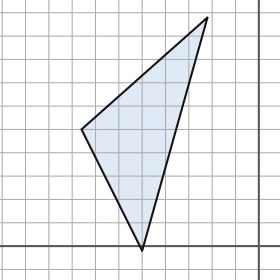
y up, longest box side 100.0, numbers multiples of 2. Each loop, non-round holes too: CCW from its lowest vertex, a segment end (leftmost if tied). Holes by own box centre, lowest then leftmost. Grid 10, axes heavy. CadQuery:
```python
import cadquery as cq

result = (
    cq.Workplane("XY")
    .moveTo(-50.0, -2.0)
    .lineTo(-22.0, 98.0)
    .lineTo(-76.0, 50.0)
    .close()
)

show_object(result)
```